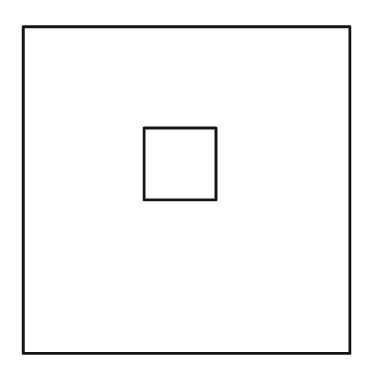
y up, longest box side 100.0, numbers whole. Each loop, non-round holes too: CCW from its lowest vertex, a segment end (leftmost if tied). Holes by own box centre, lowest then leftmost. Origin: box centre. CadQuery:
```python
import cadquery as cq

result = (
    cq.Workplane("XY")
    .moveTo(-50.0, -50.0)
    .lineTo(50.0, -50.0)
    .lineTo(50.0, 50.0)
    .lineTo(-50.0, 50.0)
    .close()
    .moveTo(-13.0, -3.0)
    .lineTo(9.0, -3.0)
    .lineTo(9.0, 19.0)
    .lineTo(-13.0, 19.0)
    .close()
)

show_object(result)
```